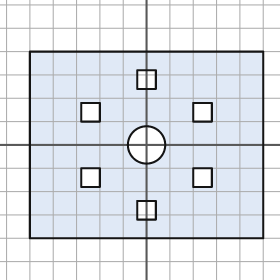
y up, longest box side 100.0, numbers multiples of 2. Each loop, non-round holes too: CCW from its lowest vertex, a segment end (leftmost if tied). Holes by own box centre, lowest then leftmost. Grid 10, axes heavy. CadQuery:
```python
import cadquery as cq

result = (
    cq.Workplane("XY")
    .moveTo(-50.0, -40.0)
    .lineTo(50.0, -40.0)
    .lineTo(50.0, 40.0)
    .lineTo(-50.0, 40.0)
    .close()
    .moveTo(-4.0, -32.0)
    .lineTo(4.0, -32.0)
    .lineTo(4.0, -24.0)
    .lineTo(-4.0, -24.0)
    .close()
    .moveTo(-28.0, -18.0)
    .lineTo(-20.0, -18.0)
    .lineTo(-20.0, -10.0)
    .lineTo(-28.0, -10.0)
    .close()
    .moveTo(20.0, -18.0)
    .lineTo(28.0, -18.0)
    .lineTo(28.0, -10.0)
    .lineTo(20.0, -10.0)
    .close()
    .moveTo(0.0, 0.0)
    .circle(8.0)
    .moveTo(-28.0, 10.0)
    .lineTo(-20.0, 10.0)
    .lineTo(-20.0, 18.0)
    .lineTo(-28.0, 18.0)
    .close()
    .moveTo(20.0, 10.0)
    .lineTo(28.0, 10.0)
    .lineTo(28.0, 18.0)
    .lineTo(20.0, 18.0)
    .close()
    .moveTo(-4.0, 24.0)
    .lineTo(4.0, 24.0)
    .lineTo(4.0, 32.0)
    .lineTo(-4.0, 32.0)
    .close()
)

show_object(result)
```